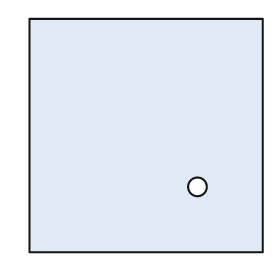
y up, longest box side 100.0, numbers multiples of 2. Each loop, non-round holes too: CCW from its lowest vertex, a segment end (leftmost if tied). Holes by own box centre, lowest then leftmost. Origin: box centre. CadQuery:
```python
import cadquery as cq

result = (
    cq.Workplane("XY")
    .moveTo(-50.0, -50.0)
    .lineTo(50.0, -50.0)
    .lineTo(50.0, 50.0)
    .lineTo(-50.0, 50.0)
    .close()
    .moveTo(22.0, -22.0)
    .circle(4.0)
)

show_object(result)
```